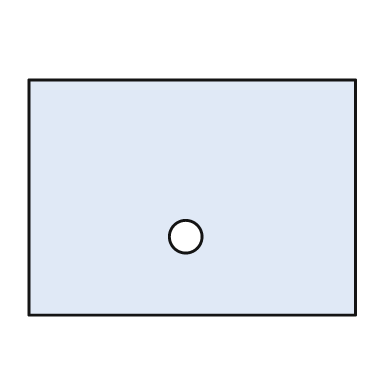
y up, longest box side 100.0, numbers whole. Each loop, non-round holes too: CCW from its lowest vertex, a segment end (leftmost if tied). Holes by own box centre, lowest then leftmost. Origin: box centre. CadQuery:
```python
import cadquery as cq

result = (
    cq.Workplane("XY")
    .moveTo(-50.0, -36.0)
    .lineTo(50.0, -36.0)
    .lineTo(50.0, 36.0)
    .lineTo(-50.0, 36.0)
    .close()
    .moveTo(-2.0, -12.0)
    .circle(5.0)
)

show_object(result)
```